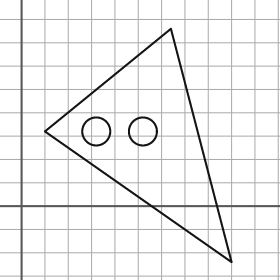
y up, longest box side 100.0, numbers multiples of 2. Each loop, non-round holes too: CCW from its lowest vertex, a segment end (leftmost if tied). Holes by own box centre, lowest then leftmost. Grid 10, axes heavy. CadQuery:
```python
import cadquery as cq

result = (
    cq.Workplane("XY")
    .moveTo(90.0, -24.0)
    .lineTo(64.0, 76.0)
    .lineTo(10.0, 32.0)
    .close()
    .moveTo(32.0, 32.0)
    .circle(6.0)
    .moveTo(52.0, 32.0)
    .circle(6.0)
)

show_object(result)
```